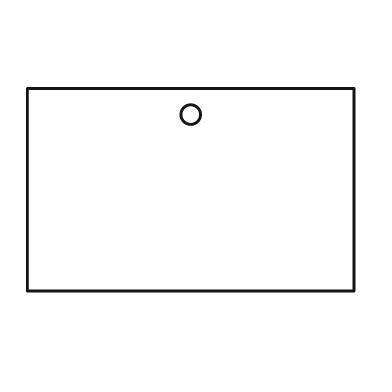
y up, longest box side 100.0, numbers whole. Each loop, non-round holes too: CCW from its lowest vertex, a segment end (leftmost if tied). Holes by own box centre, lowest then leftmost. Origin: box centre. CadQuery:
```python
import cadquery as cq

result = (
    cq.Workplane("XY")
    .moveTo(-50.0, -31.0)
    .lineTo(50.0, -31.0)
    .lineTo(50.0, 31.0)
    .lineTo(-50.0, 31.0)
    .close()
    .moveTo(0.0, 23.0)
    .circle(3.0)
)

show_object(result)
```